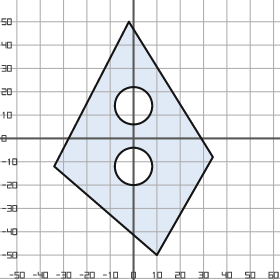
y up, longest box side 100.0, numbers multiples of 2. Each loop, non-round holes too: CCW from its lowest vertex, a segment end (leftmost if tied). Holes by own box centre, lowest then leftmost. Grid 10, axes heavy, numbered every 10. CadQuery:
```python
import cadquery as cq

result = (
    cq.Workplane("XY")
    .moveTo(10.0, -50.0)
    .lineTo(34.0, -8.0)
    .lineTo(-2.0, 50.0)
    .lineTo(-34.0, -12.0)
    .close()
    .moveTo(0.0, -12.0)
    .circle(8.0)
    .moveTo(0.0, 14.0)
    .circle(8.0)
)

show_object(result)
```